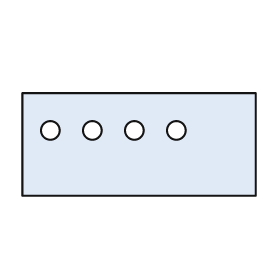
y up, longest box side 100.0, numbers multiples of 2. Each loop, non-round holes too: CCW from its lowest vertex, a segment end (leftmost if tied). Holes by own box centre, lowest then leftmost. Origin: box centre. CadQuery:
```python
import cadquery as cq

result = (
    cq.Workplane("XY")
    .moveTo(-50.0, -22.0)
    .lineTo(50.0, -22.0)
    .lineTo(50.0, 22.0)
    .lineTo(-50.0, 22.0)
    .close()
    .moveTo(-38.0, 6.0)
    .circle(4.0)
    .moveTo(-20.0, 6.0)
    .circle(4.0)
    .moveTo(-2.0, 6.0)
    .circle(4.0)
    .moveTo(16.0, 6.0)
    .circle(4.0)
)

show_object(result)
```